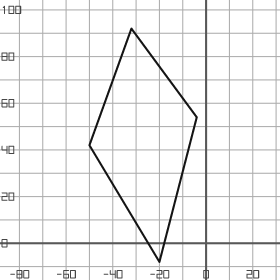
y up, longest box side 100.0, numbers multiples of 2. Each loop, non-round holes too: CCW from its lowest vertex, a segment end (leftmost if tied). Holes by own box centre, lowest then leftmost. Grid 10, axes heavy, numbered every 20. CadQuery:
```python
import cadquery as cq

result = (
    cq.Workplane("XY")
    .moveTo(-20.0, -8.0)
    .lineTo(-4.0, 54.0)
    .lineTo(-32.0, 92.0)
    .lineTo(-50.0, 42.0)
    .close()
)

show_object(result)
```